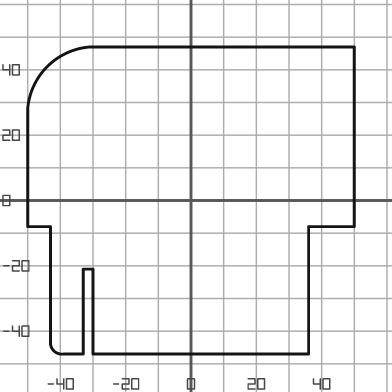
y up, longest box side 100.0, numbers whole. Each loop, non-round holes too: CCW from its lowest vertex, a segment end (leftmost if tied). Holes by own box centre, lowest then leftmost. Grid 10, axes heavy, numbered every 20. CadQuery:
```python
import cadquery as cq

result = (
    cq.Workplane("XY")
    .moveTo(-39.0, -47.0)
    .lineTo(-33.0, -47.0)
    .lineTo(-33.0, -21.0)
    .lineTo(-30.0, -21.0)
    .lineTo(-30.0, -47.0)
    .lineTo(36.0, -47.0)
    .lineTo(36.0, -8.0)
    .lineTo(50.0, -8.0)
    .lineTo(50.0, 47.0)
    .lineTo(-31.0, 47.0)
    .threePointArc((-44.0, 41.0), (-50.0, 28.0))
    .lineTo(-50.0, -8.0)
    .lineTo(-43.0, -8.0)
    .lineTo(-43.0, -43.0)
    .threePointArc((-42.0, -46.0), (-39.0, -47.0))
    .close()
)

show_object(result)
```